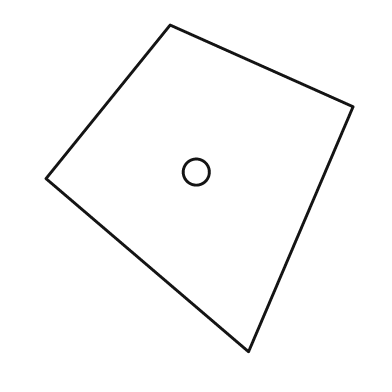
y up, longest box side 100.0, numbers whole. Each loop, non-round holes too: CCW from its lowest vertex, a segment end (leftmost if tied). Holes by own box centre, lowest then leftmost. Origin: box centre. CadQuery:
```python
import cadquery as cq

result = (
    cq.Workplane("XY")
    .moveTo(15.0, -50.0)
    .lineTo(47.0, 25.0)
    .lineTo(-9.0, 50.0)
    .lineTo(-47.0, 3.0)
    .close()
    .moveTo(-1.0, 5.0)
    .circle(4.0)
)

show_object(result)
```